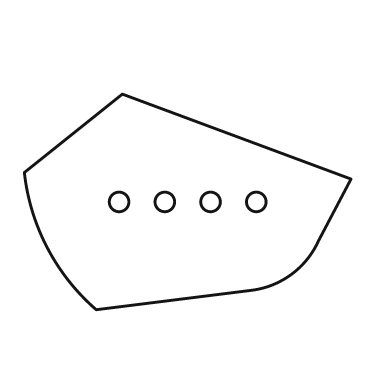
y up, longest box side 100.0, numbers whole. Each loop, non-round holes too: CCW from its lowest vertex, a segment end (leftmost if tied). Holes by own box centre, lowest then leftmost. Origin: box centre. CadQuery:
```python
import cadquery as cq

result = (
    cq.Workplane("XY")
    .moveTo(-28.0, -33.0)
    .lineTo(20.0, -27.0)
    .threePointArc((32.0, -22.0), (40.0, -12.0))
    .lineTo(50.0, 7.0)
    .lineTo(-20.0, 33.0)
    .lineTo(-50.0, 9.0)
    .threePointArc((-43.0, -14.0), (-28.0, -33.0))
    .close()
    .moveTo(-21.0, 0.0)
    .circle(3.0)
    .moveTo(-7.0, 0.0)
    .circle(3.0)
    .moveTo(7.0, 0.0)
    .circle(3.0)
    .moveTo(21.0, 0.0)
    .circle(3.0)
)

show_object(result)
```